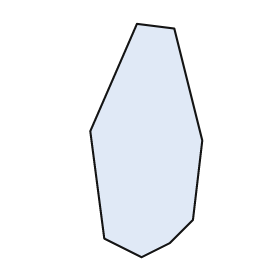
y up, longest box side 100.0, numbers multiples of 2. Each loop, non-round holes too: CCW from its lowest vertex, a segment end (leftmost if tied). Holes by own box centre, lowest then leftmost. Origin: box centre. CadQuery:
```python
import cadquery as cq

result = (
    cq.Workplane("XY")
    .moveTo(-2.0, -50.0)
    .lineTo(10.0, -44.0)
    .lineTo(20.0, -34.0)
    .lineTo(24.0, 0.0)
    .lineTo(12.0, 48.0)
    .lineTo(-4.0, 50.0)
    .lineTo(-24.0, 4.0)
    .lineTo(-18.0, -42.0)
    .close()
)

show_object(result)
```